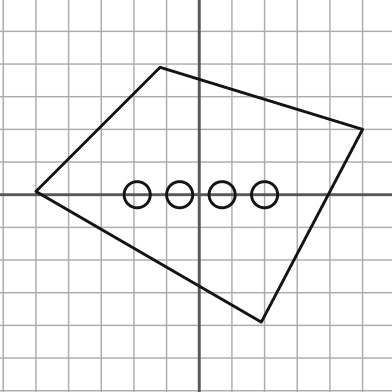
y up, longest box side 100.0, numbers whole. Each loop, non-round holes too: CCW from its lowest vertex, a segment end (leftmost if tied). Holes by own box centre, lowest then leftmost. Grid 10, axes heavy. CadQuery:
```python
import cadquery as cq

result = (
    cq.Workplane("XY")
    .moveTo(19.0, -39.0)
    .lineTo(50.0, 20.0)
    .lineTo(-12.0, 39.0)
    .lineTo(-50.0, 1.0)
    .close()
    .moveTo(-19.0, 0.0)
    .circle(4.0)
    .moveTo(-6.0, 0.0)
    .circle(4.0)
    .moveTo(7.0, 0.0)
    .circle(4.0)
    .moveTo(20.0, 0.0)
    .circle(4.0)
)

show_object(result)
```